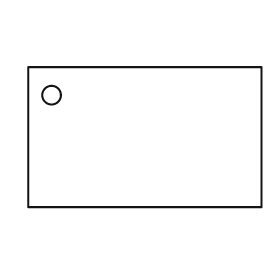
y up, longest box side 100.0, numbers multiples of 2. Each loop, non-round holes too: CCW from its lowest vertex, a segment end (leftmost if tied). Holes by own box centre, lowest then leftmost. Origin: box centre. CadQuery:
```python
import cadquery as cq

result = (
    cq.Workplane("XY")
    .moveTo(-50.0, -30.0)
    .lineTo(50.0, -30.0)
    .lineTo(50.0, 30.0)
    .lineTo(-50.0, 30.0)
    .close()
    .moveTo(-40.0, 18.0)
    .circle(4.0)
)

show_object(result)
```